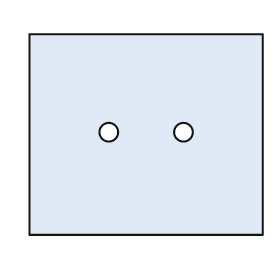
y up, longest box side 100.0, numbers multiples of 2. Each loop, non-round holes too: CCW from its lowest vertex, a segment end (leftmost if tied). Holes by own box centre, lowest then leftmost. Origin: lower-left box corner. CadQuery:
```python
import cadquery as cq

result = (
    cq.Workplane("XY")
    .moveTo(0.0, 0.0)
    .lineTo(100.0, 0.0)
    .lineTo(100.0, 86.0)
    .lineTo(0.0, 86.0)
    .close()
    .moveTo(34.0, 44.0)
    .circle(4.0)
    .moveTo(66.0, 44.0)
    .circle(4.0)
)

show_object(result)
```